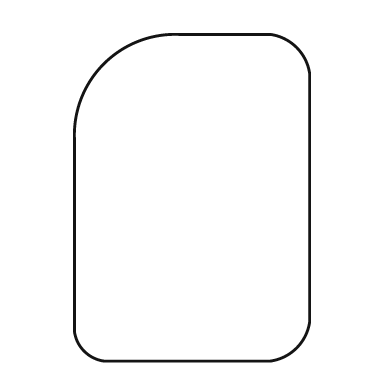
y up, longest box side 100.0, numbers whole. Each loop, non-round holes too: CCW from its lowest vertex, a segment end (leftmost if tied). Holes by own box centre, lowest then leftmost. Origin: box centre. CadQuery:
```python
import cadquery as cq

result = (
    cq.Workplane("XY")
    .moveTo(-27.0, -50.0)
    .lineTo(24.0, -50.0)
    .threePointArc((32.0, -46.0), (36.0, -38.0))
    .lineTo(36.0, 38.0)
    .threePointArc((32.0, 46.0), (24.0, 50.0))
    .lineTo(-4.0, 50.0)
    .threePointArc((-27.0, 41.0), (-36.0, 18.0))
    .lineTo(-36.0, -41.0)
    .threePointArc((-33.0, -47.0), (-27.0, -50.0))
    .close()
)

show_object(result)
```